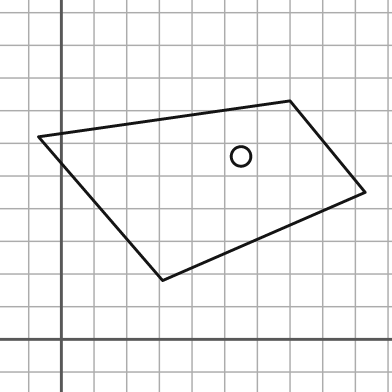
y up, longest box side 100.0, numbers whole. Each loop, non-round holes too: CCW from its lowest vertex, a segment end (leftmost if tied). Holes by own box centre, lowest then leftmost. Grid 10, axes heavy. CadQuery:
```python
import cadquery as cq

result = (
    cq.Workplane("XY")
    .moveTo(31.0, 18.0)
    .lineTo(93.0, 45.0)
    .lineTo(70.0, 73.0)
    .lineTo(-7.0, 62.0)
    .close()
    .moveTo(55.0, 56.0)
    .circle(3.0)
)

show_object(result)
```